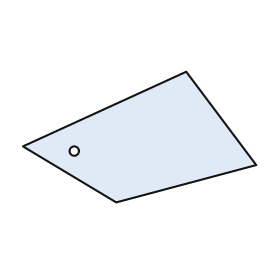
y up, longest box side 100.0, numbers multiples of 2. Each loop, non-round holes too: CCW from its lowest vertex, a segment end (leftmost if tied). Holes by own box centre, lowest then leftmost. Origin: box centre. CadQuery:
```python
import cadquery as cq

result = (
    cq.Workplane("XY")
    .moveTo(-10.0, -28.0)
    .lineTo(50.0, -12.0)
    .lineTo(20.0, 28.0)
    .lineTo(-50.0, -4.0)
    .close()
    .moveTo(-28.0, -6.0)
    .circle(2.0)
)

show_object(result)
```